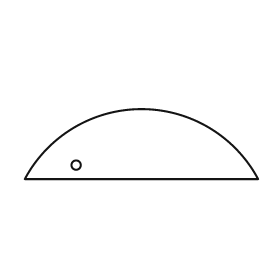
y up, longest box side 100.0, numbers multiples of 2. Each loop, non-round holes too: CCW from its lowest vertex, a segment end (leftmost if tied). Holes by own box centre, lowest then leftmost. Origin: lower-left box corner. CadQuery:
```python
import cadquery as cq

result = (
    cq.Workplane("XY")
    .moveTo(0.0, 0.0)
    .lineTo(100.0, 0.0)
    .threePointArc((50.0, 30.0), (0.0, 0.0))
    .close()
    .moveTo(22.0, 6.0)
    .circle(2.0)
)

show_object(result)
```